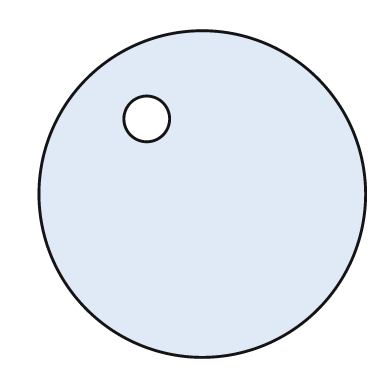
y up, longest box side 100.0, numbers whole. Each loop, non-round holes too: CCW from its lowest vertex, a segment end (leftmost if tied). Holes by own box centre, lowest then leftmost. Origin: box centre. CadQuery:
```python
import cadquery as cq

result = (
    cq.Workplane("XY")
    .moveTo(0.0, 0.0)
    .circle(50.0)
    .moveTo(-17.0, 23.0)
    .circle(7.0)
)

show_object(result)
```